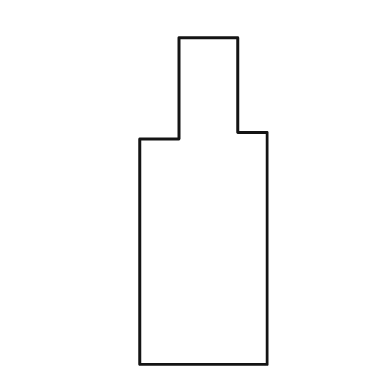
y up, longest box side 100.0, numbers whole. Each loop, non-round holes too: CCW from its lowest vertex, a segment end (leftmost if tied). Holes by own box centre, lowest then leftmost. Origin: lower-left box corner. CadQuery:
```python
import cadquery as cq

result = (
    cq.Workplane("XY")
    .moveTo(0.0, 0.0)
    .lineTo(39.0, 0.0)
    .lineTo(39.0, 71.0)
    .lineTo(30.0, 71.0)
    .lineTo(30.0, 100.0)
    .lineTo(12.0, 100.0)
    .lineTo(12.0, 69.0)
    .lineTo(0.0, 69.0)
    .close()
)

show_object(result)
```